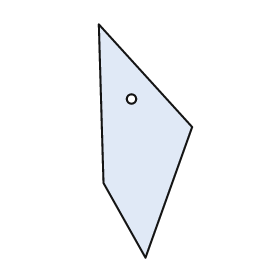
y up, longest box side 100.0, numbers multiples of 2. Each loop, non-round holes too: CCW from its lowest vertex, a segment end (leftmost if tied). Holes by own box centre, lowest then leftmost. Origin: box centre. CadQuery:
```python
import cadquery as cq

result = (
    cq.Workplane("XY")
    .moveTo(0.0, -50.0)
    .lineTo(20.0, 6.0)
    .lineTo(-20.0, 50.0)
    .lineTo(-18.0, -18.0)
    .close()
    .moveTo(-6.0, 18.0)
    .circle(2.0)
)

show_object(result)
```